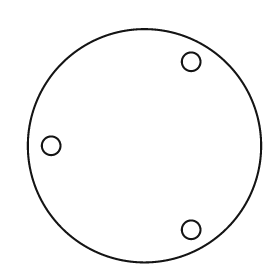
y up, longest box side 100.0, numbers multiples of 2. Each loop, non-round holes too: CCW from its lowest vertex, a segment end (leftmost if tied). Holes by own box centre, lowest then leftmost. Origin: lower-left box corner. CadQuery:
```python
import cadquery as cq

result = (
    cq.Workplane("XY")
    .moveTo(50.0, 50.0)
    .circle(50.0)
    .moveTo(70.0, 14.0)
    .circle(4.0)
    .moveTo(10.0, 50.0)
    .circle(4.0)
    .moveTo(70.0, 86.0)
    .circle(4.0)
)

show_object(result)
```